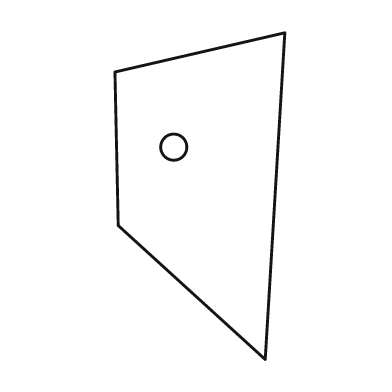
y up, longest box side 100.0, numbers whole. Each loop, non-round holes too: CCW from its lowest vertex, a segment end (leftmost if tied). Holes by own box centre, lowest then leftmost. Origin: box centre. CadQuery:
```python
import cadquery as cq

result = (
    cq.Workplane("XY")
    .moveTo(20.0, -50.0)
    .lineTo(26.0, 50.0)
    .lineTo(-26.0, 38.0)
    .lineTo(-25.0, -9.0)
    .close()
    .moveTo(-8.0, 15.0)
    .circle(4.0)
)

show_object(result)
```